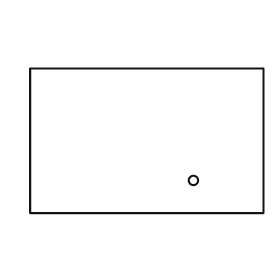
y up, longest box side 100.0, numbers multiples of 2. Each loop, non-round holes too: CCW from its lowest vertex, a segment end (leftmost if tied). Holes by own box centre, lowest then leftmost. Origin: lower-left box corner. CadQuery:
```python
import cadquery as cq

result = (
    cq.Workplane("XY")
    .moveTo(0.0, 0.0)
    .lineTo(100.0, 0.0)
    .lineTo(100.0, 62.0)
    .lineTo(0.0, 62.0)
    .close()
    .moveTo(70.0, 14.0)
    .circle(2.0)
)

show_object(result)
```